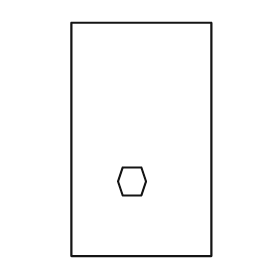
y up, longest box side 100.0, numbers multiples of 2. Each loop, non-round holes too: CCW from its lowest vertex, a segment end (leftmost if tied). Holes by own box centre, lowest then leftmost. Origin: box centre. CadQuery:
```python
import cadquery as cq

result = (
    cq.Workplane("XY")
    .moveTo(-30.0, -50.0)
    .lineTo(30.0, -50.0)
    .lineTo(30.0, 50.0)
    .lineTo(-30.0, 50.0)
    .close()
    .moveTo(-8.0, -24.0)
    .lineTo(0.0, -24.0)
    .lineTo(2.0, -18.0)
    .lineTo(0.0, -12.0)
    .lineTo(-8.0, -12.0)
    .lineTo(-10.0, -18.0)
    .close()
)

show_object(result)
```